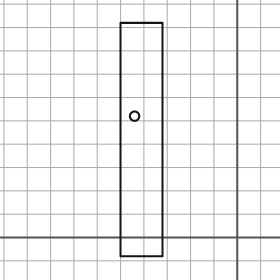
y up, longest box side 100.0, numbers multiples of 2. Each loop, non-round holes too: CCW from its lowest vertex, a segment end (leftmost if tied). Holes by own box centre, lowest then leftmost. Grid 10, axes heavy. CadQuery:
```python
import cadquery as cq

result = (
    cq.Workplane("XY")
    .moveTo(-50.0, -8.0)
    .lineTo(-32.0, -8.0)
    .lineTo(-32.0, 92.0)
    .lineTo(-50.0, 92.0)
    .close()
    .moveTo(-44.0, 52.0)
    .circle(2.0)
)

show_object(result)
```